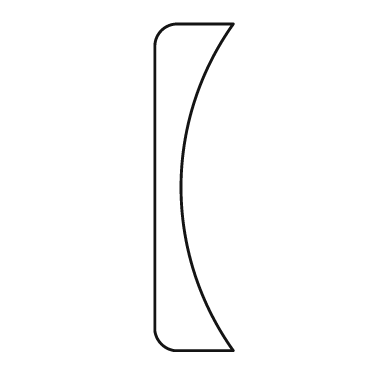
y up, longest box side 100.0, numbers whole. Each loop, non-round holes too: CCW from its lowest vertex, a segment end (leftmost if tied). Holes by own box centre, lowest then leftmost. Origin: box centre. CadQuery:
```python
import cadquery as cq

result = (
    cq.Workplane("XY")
    .moveTo(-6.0, -50.0)
    .lineTo(12.0, -50.0)
    .threePointArc((-4.0, 0.0), (12.0, 50.0))
    .lineTo(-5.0, 50.0)
    .threePointArc((-10.0, 48.0), (-12.0, 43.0))
    .lineTo(-12.0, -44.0)
    .threePointArc((-10.0, -48.0), (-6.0, -50.0))
    .close()
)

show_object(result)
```